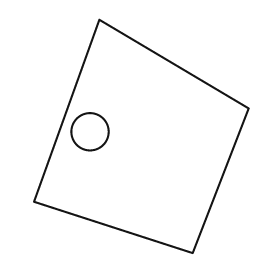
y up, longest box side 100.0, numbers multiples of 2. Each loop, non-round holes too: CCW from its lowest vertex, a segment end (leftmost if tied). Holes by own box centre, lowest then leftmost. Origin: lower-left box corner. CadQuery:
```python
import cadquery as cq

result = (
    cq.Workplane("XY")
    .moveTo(68.0, 0.0)
    .lineTo(92.0, 62.0)
    .lineTo(28.0, 100.0)
    .lineTo(0.0, 22.0)
    .close()
    .moveTo(24.0, 52.0)
    .circle(8.0)
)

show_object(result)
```